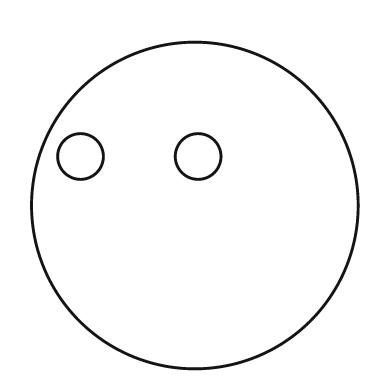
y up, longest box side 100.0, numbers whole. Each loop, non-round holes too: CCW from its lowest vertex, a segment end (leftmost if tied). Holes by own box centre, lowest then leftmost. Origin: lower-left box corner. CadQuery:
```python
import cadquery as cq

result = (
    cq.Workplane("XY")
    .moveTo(50.0, 50.0)
    .circle(50.0)
    .moveTo(15.0, 65.0)
    .circle(7.0)
    .moveTo(51.0, 65.0)
    .circle(7.0)
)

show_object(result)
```